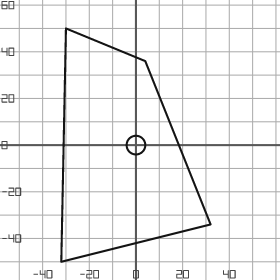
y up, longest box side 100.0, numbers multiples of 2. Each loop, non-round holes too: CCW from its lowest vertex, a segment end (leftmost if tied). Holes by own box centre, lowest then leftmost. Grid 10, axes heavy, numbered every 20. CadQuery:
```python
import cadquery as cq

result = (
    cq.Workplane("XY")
    .moveTo(-32.0, -50.0)
    .lineTo(32.0, -34.0)
    .lineTo(4.0, 36.0)
    .lineTo(-30.0, 50.0)
    .close()
    .moveTo(0.0, 0.0)
    .circle(4.0)
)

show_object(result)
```